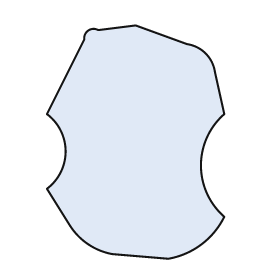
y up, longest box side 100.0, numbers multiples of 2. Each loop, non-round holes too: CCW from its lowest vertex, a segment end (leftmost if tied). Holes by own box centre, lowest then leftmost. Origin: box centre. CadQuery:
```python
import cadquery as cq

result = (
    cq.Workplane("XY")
    .moveTo(14.0, -50.0)
    .threePointArc((28.0, -44.0), (38.0, -32.0))
    .threePointArc((28.0, -10.0), (38.0, 12.0))
    .lineTo(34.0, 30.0)
    .threePointArc((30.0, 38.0), (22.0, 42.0))
    .lineTo(0.0, 50.0)
    .lineTo(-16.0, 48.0)
    .threePointArc((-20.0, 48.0), (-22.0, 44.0))
    .lineTo(-38.0, 12.0)
    .threePointArc((-30.0, -4.0), (-38.0, -20.0))
    .lineTo(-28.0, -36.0)
    .threePointArc((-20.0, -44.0), (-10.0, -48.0))
    .close()
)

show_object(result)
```